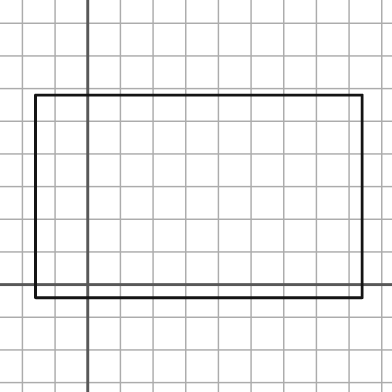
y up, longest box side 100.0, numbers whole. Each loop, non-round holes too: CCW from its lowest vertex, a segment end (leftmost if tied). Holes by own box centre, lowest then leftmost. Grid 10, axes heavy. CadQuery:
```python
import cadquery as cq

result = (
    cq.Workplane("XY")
    .moveTo(-16.0, -4.0)
    .lineTo(84.0, -4.0)
    .lineTo(84.0, 58.0)
    .lineTo(-16.0, 58.0)
    .close()
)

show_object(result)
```